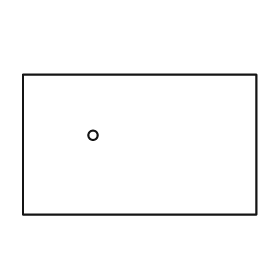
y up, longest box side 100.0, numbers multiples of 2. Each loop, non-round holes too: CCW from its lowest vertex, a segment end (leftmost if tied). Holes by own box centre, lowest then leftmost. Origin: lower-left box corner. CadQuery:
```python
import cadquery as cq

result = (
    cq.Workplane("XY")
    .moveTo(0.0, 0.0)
    .lineTo(100.0, 0.0)
    .lineTo(100.0, 60.0)
    .lineTo(0.0, 60.0)
    .close()
    .moveTo(30.0, 34.0)
    .circle(2.0)
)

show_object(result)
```